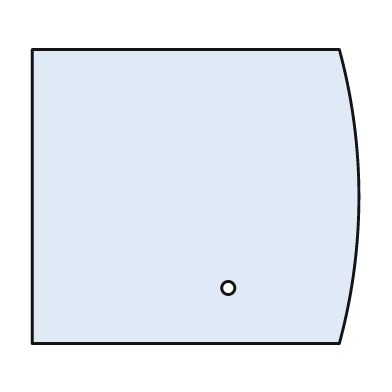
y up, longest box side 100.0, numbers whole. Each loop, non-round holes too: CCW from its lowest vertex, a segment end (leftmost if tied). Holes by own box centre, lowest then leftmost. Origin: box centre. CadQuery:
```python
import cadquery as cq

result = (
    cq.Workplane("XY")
    .moveTo(-50.0, -45.0)
    .lineTo(44.0, -45.0)
    .threePointArc((50.0, 0.0), (44.0, 45.0))
    .lineTo(-50.0, 45.0)
    .close()
    .moveTo(10.0, -28.0)
    .circle(2.0)
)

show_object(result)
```